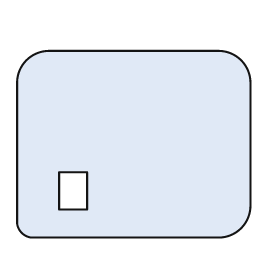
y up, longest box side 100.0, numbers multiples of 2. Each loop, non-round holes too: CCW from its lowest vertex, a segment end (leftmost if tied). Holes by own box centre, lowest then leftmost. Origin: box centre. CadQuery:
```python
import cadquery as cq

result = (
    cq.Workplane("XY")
    .moveTo(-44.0, -40.0)
    .lineTo(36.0, -40.0)
    .threePointArc((46.0, -36.0), (50.0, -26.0))
    .lineTo(50.0, 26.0)
    .threePointArc((46.0, 36.0), (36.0, 40.0))
    .lineTo(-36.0, 40.0)
    .threePointArc((-46.0, 36.0), (-50.0, 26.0))
    .lineTo(-50.0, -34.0)
    .threePointArc((-48.0, -38.0), (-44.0, -40.0))
    .close()
    .moveTo(-32.0, -28.0)
    .lineTo(-20.0, -28.0)
    .lineTo(-20.0, -12.0)
    .lineTo(-32.0, -12.0)
    .close()
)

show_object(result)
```